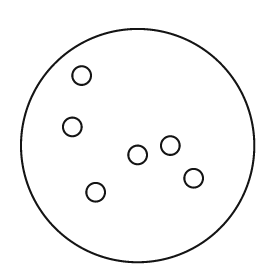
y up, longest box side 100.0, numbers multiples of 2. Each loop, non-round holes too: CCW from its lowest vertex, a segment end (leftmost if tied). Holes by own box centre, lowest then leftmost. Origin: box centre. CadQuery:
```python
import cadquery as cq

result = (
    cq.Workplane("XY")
    .moveTo(0.0, 0.0)
    .circle(50.0)
    .moveTo(-18.0, -20.0)
    .circle(4.0)
    .moveTo(24.0, -14.0)
    .circle(4.0)
    .moveTo(0.0, -4.0)
    .circle(4.0)
    .moveTo(14.0, 0.0)
    .circle(4.0)
    .moveTo(-28.0, 8.0)
    .circle(4.0)
    .moveTo(-24.0, 30.0)
    .circle(4.0)
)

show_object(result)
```